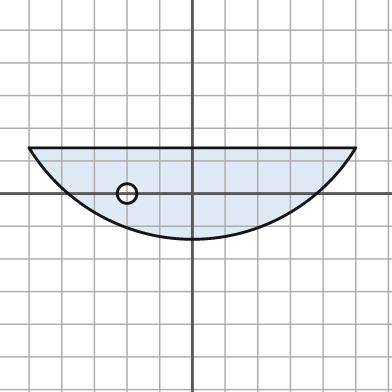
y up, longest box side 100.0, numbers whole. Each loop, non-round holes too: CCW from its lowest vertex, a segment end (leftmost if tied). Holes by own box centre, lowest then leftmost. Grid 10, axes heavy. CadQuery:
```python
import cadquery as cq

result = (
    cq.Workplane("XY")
    .moveTo(-50.0, 14.0)
    .threePointArc((0.0, -14.0), (50.0, 14.0))
    .close()
    .moveTo(-20.0, 0.0)
    .circle(3.0)
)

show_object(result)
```